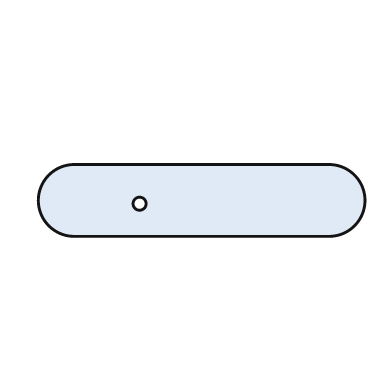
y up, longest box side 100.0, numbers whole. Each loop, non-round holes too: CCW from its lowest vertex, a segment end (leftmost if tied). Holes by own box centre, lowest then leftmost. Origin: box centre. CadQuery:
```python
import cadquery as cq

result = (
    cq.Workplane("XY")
    .moveTo(-39.0, -11.0)
    .lineTo(39.0, -11.0)
    .threePointArc((50.0, 0.0), (39.0, 11.0))
    .lineTo(-39.0, 11.0)
    .threePointArc((-50.0, 0.0), (-39.0, -11.0))
    .close()
    .moveTo(-19.0, -1.0)
    .circle(2.0)
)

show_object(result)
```